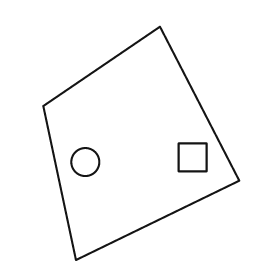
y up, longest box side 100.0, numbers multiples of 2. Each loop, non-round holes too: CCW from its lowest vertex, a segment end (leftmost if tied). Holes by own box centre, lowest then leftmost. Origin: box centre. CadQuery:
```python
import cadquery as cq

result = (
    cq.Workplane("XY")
    .moveTo(-28.0, -50.0)
    .lineTo(42.0, -16.0)
    .lineTo(8.0, 50.0)
    .lineTo(-42.0, 16.0)
    .close()
    .moveTo(-24.0, -8.0)
    .circle(6.0)
    .moveTo(16.0, -12.0)
    .lineTo(28.0, -12.0)
    .lineTo(28.0, 0.0)
    .lineTo(16.0, 0.0)
    .close()
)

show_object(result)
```